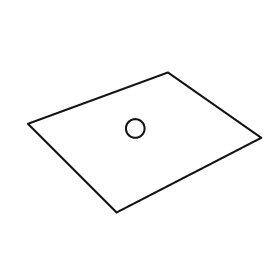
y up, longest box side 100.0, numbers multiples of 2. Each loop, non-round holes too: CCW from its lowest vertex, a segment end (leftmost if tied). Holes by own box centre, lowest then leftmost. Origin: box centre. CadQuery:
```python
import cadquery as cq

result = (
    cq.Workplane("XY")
    .moveTo(-12.0, -30.0)
    .lineTo(50.0, 2.0)
    .lineTo(10.0, 30.0)
    .lineTo(-50.0, 8.0)
    .close()
    .moveTo(-4.0, 6.0)
    .circle(4.0)
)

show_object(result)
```